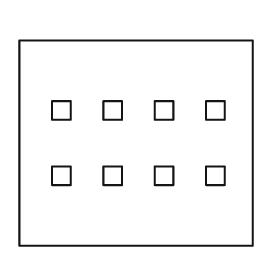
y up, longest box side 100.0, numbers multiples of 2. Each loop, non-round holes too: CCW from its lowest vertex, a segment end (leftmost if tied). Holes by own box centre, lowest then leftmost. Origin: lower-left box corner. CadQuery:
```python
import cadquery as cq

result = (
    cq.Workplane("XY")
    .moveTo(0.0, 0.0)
    .lineTo(100.0, 0.0)
    .lineTo(100.0, 88.0)
    .lineTo(0.0, 88.0)
    .close()
    .moveTo(14.0, 26.0)
    .lineTo(22.0, 26.0)
    .lineTo(22.0, 34.0)
    .lineTo(14.0, 34.0)
    .close()
    .moveTo(36.0, 26.0)
    .lineTo(44.0, 26.0)
    .lineTo(44.0, 34.0)
    .lineTo(36.0, 34.0)
    .close()
    .moveTo(58.0, 26.0)
    .lineTo(66.0, 26.0)
    .lineTo(66.0, 34.0)
    .lineTo(58.0, 34.0)
    .close()
    .moveTo(80.0, 26.0)
    .lineTo(88.0, 26.0)
    .lineTo(88.0, 34.0)
    .lineTo(80.0, 34.0)
    .close()
    .moveTo(14.0, 54.0)
    .lineTo(22.0, 54.0)
    .lineTo(22.0, 62.0)
    .lineTo(14.0, 62.0)
    .close()
    .moveTo(36.0, 54.0)
    .lineTo(44.0, 54.0)
    .lineTo(44.0, 62.0)
    .lineTo(36.0, 62.0)
    .close()
    .moveTo(58.0, 54.0)
    .lineTo(66.0, 54.0)
    .lineTo(66.0, 62.0)
    .lineTo(58.0, 62.0)
    .close()
    .moveTo(80.0, 54.0)
    .lineTo(88.0, 54.0)
    .lineTo(88.0, 62.0)
    .lineTo(80.0, 62.0)
    .close()
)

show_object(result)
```